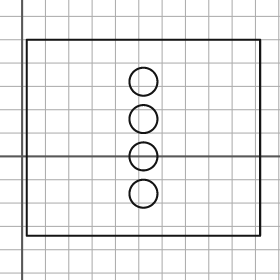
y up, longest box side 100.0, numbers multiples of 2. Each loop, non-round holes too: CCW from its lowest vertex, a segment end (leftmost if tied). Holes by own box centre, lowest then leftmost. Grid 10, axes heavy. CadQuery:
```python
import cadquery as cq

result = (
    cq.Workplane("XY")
    .moveTo(2.0, -34.0)
    .lineTo(102.0, -34.0)
    .lineTo(102.0, 50.0)
    .lineTo(2.0, 50.0)
    .close()
    .moveTo(52.0, -16.0)
    .circle(6.0)
    .moveTo(52.0, 0.0)
    .circle(6.0)
    .moveTo(52.0, 16.0)
    .circle(6.0)
    .moveTo(52.0, 32.0)
    .circle(6.0)
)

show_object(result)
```